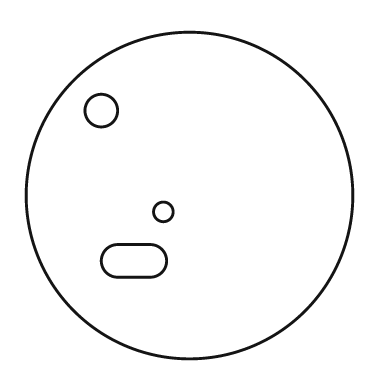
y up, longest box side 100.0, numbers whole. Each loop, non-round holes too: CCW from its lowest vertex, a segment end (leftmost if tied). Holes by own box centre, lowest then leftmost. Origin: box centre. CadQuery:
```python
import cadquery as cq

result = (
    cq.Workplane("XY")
    .moveTo(0.0, 0.0)
    .circle(50.0)
    .moveTo(-22.0, -25.0)
    .lineTo(-12.0, -25.0)
    .threePointArc((-7.0, -20.0), (-12.0, -15.0))
    .lineTo(-22.0, -15.0)
    .threePointArc((-27.0, -20.0), (-22.0, -25.0))
    .close()
    .moveTo(-8.0, -5.0)
    .circle(3.0)
    .moveTo(-27.0, 26.0)
    .circle(5.0)
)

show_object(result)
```